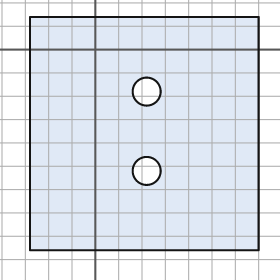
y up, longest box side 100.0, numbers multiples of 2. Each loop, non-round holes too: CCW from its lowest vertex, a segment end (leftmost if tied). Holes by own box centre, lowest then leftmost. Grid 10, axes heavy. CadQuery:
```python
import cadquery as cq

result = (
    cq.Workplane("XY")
    .moveTo(-28.0, -86.0)
    .lineTo(70.0, -86.0)
    .lineTo(70.0, 14.0)
    .lineTo(-28.0, 14.0)
    .close()
    .moveTo(22.0, -52.0)
    .circle(6.0)
    .moveTo(22.0, -18.0)
    .circle(6.0)
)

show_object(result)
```